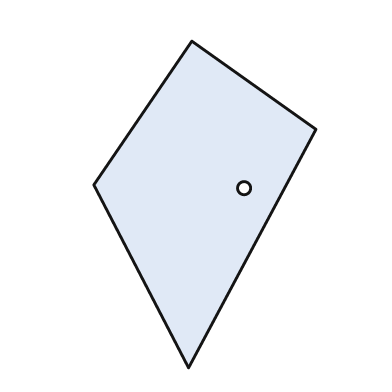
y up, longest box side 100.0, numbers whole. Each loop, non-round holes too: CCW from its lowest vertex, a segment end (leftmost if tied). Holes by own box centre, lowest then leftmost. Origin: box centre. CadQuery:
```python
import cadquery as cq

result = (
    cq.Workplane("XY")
    .moveTo(-5.0, -50.0)
    .lineTo(34.0, 23.0)
    .lineTo(-4.0, 50.0)
    .lineTo(-34.0, 6.0)
    .close()
    .moveTo(12.0, 5.0)
    .circle(2.0)
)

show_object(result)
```